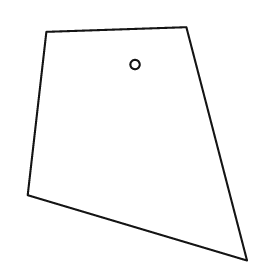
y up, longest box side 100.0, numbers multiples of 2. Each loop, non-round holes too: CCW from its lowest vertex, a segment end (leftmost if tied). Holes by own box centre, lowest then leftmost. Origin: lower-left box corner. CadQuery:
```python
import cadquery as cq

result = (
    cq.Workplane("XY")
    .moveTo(94.0, 0.0)
    .lineTo(68.0, 100.0)
    .lineTo(8.0, 98.0)
    .lineTo(0.0, 28.0)
    .close()
    .moveTo(46.0, 84.0)
    .circle(2.0)
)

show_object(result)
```